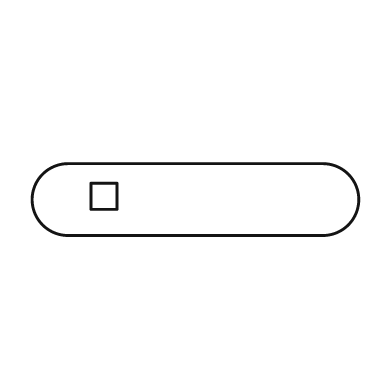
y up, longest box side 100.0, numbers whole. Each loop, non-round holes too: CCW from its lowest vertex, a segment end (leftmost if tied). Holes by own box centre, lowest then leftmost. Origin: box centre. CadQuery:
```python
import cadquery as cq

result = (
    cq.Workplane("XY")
    .moveTo(-39.0, -11.0)
    .lineTo(39.0, -11.0)
    .threePointArc((50.0, 0.0), (39.0, 11.0))
    .lineTo(-39.0, 11.0)
    .threePointArc((-50.0, 0.0), (-39.0, -11.0))
    .close()
    .moveTo(-32.0, -3.0)
    .lineTo(-24.0, -3.0)
    .lineTo(-24.0, 5.0)
    .lineTo(-32.0, 5.0)
    .close()
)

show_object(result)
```